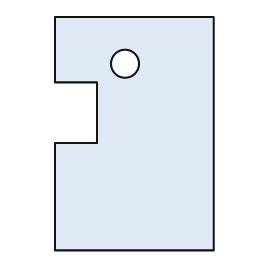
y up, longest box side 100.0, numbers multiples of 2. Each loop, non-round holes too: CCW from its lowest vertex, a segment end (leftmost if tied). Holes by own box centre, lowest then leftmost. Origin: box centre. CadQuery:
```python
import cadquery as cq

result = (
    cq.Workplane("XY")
    .moveTo(-34.0, -50.0)
    .lineTo(34.0, -50.0)
    .lineTo(34.0, 50.0)
    .lineTo(-34.0, 50.0)
    .lineTo(-34.0, 22.0)
    .lineTo(-16.0, 22.0)
    .lineTo(-16.0, -4.0)
    .lineTo(-34.0, -4.0)
    .close()
    .moveTo(-4.0, 30.0)
    .circle(6.0)
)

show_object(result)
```